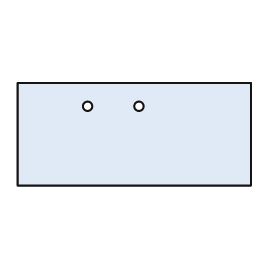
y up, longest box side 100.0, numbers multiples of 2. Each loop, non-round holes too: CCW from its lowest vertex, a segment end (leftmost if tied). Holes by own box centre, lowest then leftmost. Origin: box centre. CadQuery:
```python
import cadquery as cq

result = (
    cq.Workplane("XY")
    .moveTo(-50.0, -22.0)
    .lineTo(50.0, -22.0)
    .lineTo(50.0, 22.0)
    .lineTo(-50.0, 22.0)
    .close()
    .moveTo(-20.0, 12.0)
    .circle(2.0)
    .moveTo(2.0, 12.0)
    .circle(2.0)
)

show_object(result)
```